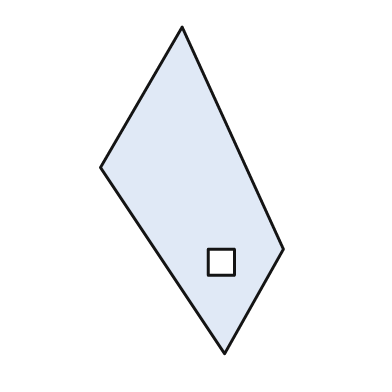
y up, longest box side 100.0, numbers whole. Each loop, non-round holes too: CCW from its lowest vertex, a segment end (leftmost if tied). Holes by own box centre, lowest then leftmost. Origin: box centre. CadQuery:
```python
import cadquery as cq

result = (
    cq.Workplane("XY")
    .moveTo(10.0, -50.0)
    .lineTo(28.0, -18.0)
    .lineTo(-3.0, 50.0)
    .lineTo(-28.0, 7.0)
    .close()
    .moveTo(5.0, -26.0)
    .lineTo(13.0, -26.0)
    .lineTo(13.0, -18.0)
    .lineTo(5.0, -18.0)
    .close()
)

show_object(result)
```